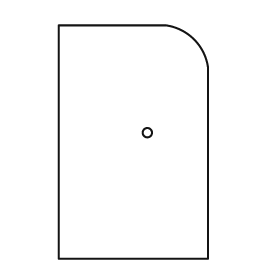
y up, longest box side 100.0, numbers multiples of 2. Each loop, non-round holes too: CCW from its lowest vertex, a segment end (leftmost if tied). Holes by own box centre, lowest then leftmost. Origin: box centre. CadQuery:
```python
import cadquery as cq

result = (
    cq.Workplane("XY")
    .moveTo(-32.0, -50.0)
    .lineTo(32.0, -50.0)
    .lineTo(32.0, 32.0)
    .threePointArc((26.0, 44.0), (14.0, 50.0))
    .lineTo(-32.0, 50.0)
    .close()
    .moveTo(6.0, 4.0)
    .circle(2.0)
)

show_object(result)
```